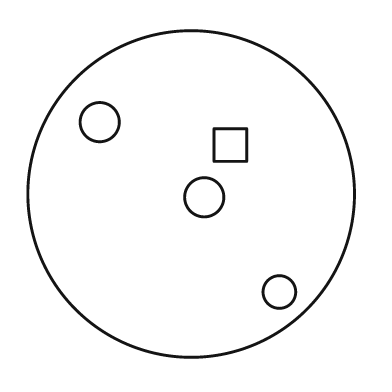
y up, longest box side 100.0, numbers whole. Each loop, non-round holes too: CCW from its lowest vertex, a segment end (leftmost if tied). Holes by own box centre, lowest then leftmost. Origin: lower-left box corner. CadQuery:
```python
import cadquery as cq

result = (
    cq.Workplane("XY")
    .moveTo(50.0, 50.0)
    .circle(50.0)
    .moveTo(77.0, 20.0)
    .circle(5.0)
    .moveTo(54.0, 49.0)
    .circle(6.0)
    .moveTo(57.0, 60.0)
    .lineTo(67.0, 60.0)
    .lineTo(67.0, 70.0)
    .lineTo(57.0, 70.0)
    .close()
    .moveTo(22.0, 72.0)
    .circle(6.0)
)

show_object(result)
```